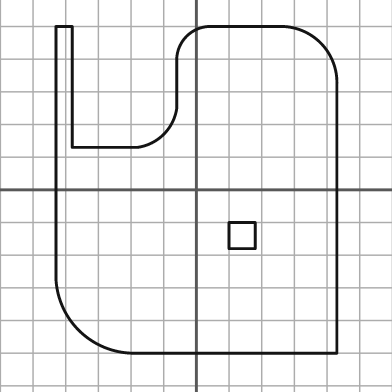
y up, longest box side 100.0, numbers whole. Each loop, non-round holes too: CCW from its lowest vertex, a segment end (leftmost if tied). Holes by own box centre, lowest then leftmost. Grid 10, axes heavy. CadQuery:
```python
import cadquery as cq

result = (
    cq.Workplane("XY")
    .moveTo(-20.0, -50.0)
    .lineTo(43.0, -50.0)
    .lineTo(43.0, 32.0)
    .threePointArc((38.0, 45.0), (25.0, 50.0))
    .lineTo(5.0, 50.0)
    .threePointArc((-3.0, 47.0), (-6.0, 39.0))
    .lineTo(-6.0, 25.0)
    .threePointArc((-10.0, 17.0), (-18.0, 13.0))
    .lineTo(-38.0, 13.0)
    .lineTo(-38.0, 50.0)
    .lineTo(-43.0, 50.0)
    .lineTo(-43.0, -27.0)
    .threePointArc((-36.0, -43.0), (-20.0, -50.0))
    .close()
    .moveTo(10.0, -18.0)
    .lineTo(18.0, -18.0)
    .lineTo(18.0, -10.0)
    .lineTo(10.0, -10.0)
    .close()
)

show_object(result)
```